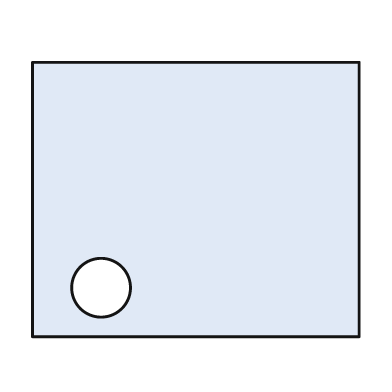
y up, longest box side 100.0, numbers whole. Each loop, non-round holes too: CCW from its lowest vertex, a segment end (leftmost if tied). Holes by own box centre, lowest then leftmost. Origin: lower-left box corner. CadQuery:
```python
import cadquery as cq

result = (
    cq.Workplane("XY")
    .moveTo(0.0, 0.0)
    .lineTo(100.0, 0.0)
    .lineTo(100.0, 84.0)
    .lineTo(0.0, 84.0)
    .close()
    .moveTo(21.0, 15.0)
    .circle(9.0)
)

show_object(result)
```